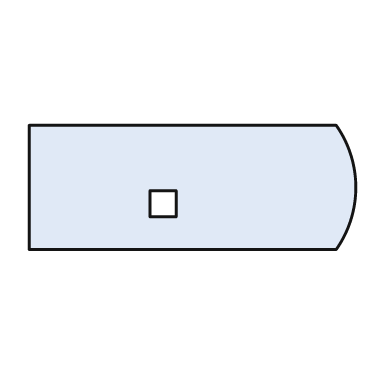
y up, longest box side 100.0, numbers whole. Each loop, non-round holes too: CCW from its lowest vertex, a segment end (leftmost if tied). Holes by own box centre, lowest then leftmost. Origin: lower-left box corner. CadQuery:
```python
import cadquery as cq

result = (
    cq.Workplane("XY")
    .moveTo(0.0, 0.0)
    .lineTo(94.0, 0.0)
    .threePointArc((100.0, 19.0), (94.0, 38.0))
    .lineTo(0.0, 38.0)
    .close()
    .moveTo(37.0, 10.0)
    .lineTo(45.0, 10.0)
    .lineTo(45.0, 18.0)
    .lineTo(37.0, 18.0)
    .close()
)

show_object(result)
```